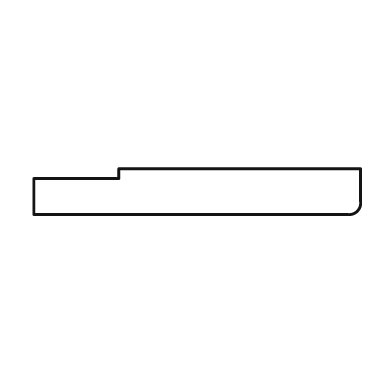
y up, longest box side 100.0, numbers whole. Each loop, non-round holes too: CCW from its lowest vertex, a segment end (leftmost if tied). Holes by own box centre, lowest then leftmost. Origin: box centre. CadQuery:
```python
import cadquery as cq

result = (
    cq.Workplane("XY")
    .moveTo(-50.0, -7.0)
    .lineTo(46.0, -7.0)
    .threePointArc((49.0, -6.0), (50.0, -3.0))
    .lineTo(50.0, 7.0)
    .lineTo(-24.0, 7.0)
    .lineTo(-24.0, 4.0)
    .lineTo(-50.0, 4.0)
    .close()
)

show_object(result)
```